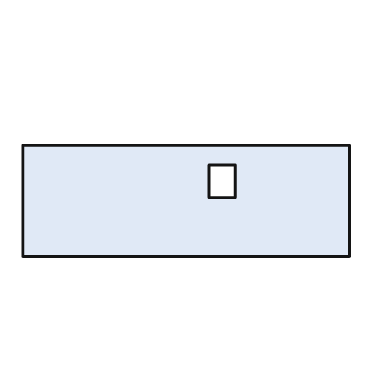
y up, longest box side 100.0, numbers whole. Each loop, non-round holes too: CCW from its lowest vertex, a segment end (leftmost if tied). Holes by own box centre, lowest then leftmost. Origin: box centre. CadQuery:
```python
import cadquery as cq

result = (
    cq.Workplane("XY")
    .moveTo(-50.0, -17.0)
    .lineTo(50.0, -17.0)
    .lineTo(50.0, 17.0)
    .lineTo(-50.0, 17.0)
    .close()
    .moveTo(7.0, 1.0)
    .lineTo(15.0, 1.0)
    .lineTo(15.0, 11.0)
    .lineTo(7.0, 11.0)
    .close()
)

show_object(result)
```